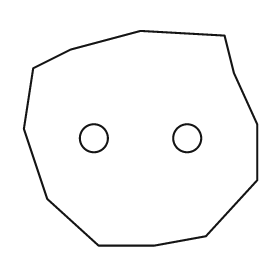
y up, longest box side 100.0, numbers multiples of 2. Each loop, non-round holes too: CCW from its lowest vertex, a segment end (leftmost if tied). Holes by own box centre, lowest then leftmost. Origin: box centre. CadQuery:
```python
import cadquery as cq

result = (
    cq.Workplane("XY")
    .moveTo(-18.0, -46.0)
    .lineTo(6.0, -46.0)
    .lineTo(28.0, -42.0)
    .lineTo(50.0, -18.0)
    .lineTo(50.0, 6.0)
    .lineTo(40.0, 28.0)
    .lineTo(36.0, 44.0)
    .lineTo(0.0, 46.0)
    .lineTo(-30.0, 38.0)
    .lineTo(-46.0, 30.0)
    .lineTo(-50.0, 4.0)
    .lineTo(-40.0, -26.0)
    .close()
    .moveTo(-20.0, 0.0)
    .circle(6.0)
    .moveTo(20.0, 0.0)
    .circle(6.0)
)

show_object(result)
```